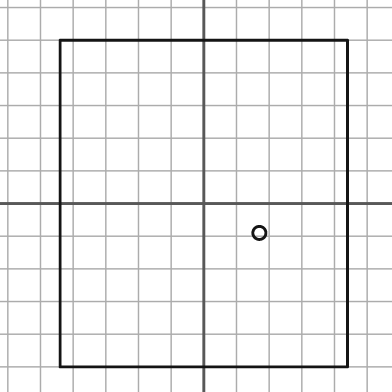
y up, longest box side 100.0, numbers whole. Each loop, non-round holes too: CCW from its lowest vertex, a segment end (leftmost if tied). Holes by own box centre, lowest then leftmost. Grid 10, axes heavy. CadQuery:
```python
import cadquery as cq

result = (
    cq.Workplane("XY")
    .moveTo(-44.0, -50.0)
    .lineTo(44.0, -50.0)
    .lineTo(44.0, 50.0)
    .lineTo(-44.0, 50.0)
    .close()
    .moveTo(17.0, -9.0)
    .circle(2.0)
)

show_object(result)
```